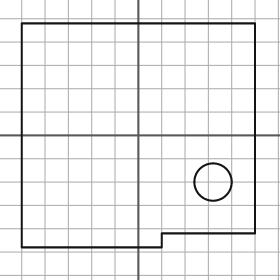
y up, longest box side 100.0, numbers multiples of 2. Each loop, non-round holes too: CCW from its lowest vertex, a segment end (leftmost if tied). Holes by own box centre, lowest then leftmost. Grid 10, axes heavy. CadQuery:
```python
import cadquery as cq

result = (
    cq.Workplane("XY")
    .moveTo(-50.0, -48.0)
    .lineTo(10.0, -48.0)
    .lineTo(10.0, -42.0)
    .lineTo(50.0, -42.0)
    .lineTo(50.0, 48.0)
    .lineTo(-50.0, 48.0)
    .close()
    .moveTo(32.0, -20.0)
    .circle(8.0)
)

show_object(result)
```